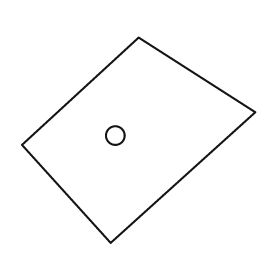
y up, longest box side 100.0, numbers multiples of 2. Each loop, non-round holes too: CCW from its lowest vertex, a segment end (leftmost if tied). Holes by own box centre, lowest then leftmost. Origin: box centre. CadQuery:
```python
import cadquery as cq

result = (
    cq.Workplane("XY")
    .moveTo(-12.0, -44.0)
    .lineTo(50.0, 12.0)
    .lineTo(0.0, 44.0)
    .lineTo(-50.0, -2.0)
    .close()
    .moveTo(-10.0, 2.0)
    .circle(4.0)
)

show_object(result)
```